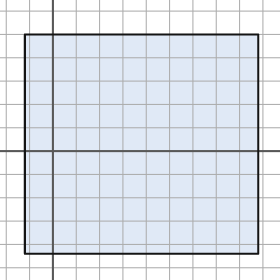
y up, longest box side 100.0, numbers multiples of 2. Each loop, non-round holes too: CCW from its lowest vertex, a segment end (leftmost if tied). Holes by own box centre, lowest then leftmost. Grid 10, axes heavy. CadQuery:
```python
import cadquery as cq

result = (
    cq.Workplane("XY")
    .moveTo(-12.0, -44.0)
    .lineTo(88.0, -44.0)
    .lineTo(88.0, 50.0)
    .lineTo(-12.0, 50.0)
    .close()
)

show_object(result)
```